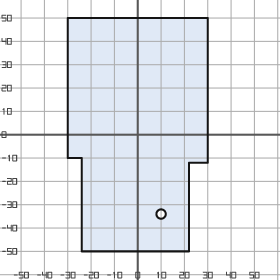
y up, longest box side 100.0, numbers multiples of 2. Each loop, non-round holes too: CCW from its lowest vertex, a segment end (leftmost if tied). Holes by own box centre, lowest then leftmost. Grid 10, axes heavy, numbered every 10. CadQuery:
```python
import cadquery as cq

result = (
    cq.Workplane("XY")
    .moveTo(-24.0, -50.0)
    .lineTo(22.0, -50.0)
    .lineTo(22.0, -12.0)
    .lineTo(30.0, -12.0)
    .lineTo(30.0, 50.0)
    .lineTo(-30.0, 50.0)
    .lineTo(-30.0, -10.0)
    .lineTo(-24.0, -10.0)
    .close()
    .moveTo(10.0, -34.0)
    .circle(2.0)
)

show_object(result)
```